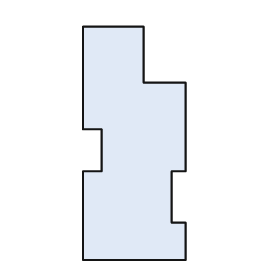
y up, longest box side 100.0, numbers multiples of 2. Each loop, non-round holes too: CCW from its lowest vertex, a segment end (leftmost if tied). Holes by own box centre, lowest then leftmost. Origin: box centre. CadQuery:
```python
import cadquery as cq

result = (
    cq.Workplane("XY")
    .moveTo(-22.0, -50.0)
    .lineTo(22.0, -50.0)
    .lineTo(22.0, -34.0)
    .lineTo(16.0, -34.0)
    .lineTo(16.0, -12.0)
    .lineTo(22.0, -12.0)
    .lineTo(22.0, 26.0)
    .lineTo(4.0, 26.0)
    .lineTo(4.0, 50.0)
    .lineTo(-22.0, 50.0)
    .lineTo(-22.0, 6.0)
    .lineTo(-14.0, 6.0)
    .lineTo(-14.0, -12.0)
    .lineTo(-22.0, -12.0)
    .close()
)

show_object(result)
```